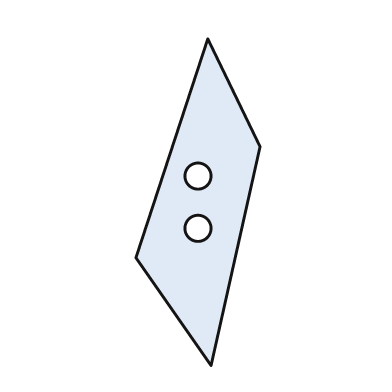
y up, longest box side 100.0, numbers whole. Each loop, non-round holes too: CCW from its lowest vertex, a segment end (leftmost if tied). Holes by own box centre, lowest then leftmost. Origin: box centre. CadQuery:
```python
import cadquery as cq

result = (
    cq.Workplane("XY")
    .moveTo(4.0, -50.0)
    .lineTo(19.0, 17.0)
    .lineTo(3.0, 50.0)
    .lineTo(-19.0, -17.0)
    .close()
    .moveTo(0.0, -8.0)
    .circle(4.0)
    .moveTo(0.0, 8.0)
    .circle(4.0)
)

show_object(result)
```